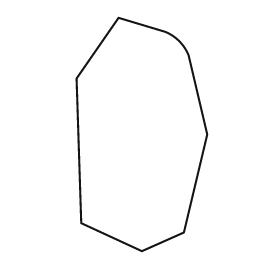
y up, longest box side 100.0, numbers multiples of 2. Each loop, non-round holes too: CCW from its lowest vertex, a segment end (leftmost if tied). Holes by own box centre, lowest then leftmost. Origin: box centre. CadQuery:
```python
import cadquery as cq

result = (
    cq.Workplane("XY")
    .moveTo(0.0, -50.0)
    .lineTo(18.0, -42.0)
    .lineTo(28.0, 0.0)
    .lineTo(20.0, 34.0)
    .threePointArc((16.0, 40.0), (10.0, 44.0))
    .lineTo(-10.0, 50.0)
    .lineTo(-28.0, 24.0)
    .lineTo(-26.0, -38.0)
    .close()
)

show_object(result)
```